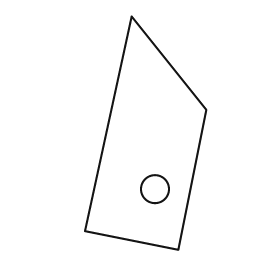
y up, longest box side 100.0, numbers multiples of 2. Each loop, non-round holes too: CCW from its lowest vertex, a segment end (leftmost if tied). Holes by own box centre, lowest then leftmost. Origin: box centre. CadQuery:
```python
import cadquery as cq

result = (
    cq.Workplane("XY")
    .moveTo(14.0, -50.0)
    .lineTo(26.0, 10.0)
    .lineTo(-6.0, 50.0)
    .lineTo(-26.0, -42.0)
    .close()
    .moveTo(4.0, -24.0)
    .circle(6.0)
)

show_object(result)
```